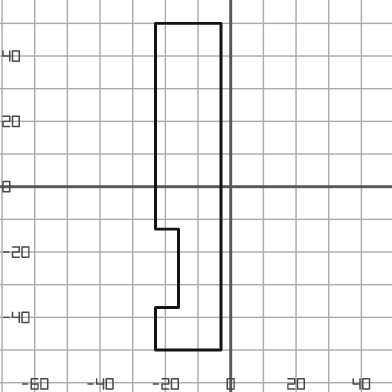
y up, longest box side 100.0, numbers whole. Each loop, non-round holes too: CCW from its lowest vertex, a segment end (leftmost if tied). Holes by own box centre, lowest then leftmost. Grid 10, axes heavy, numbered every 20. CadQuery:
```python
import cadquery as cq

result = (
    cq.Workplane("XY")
    .moveTo(-23.0, -50.0)
    .lineTo(-3.0, -50.0)
    .lineTo(-3.0, 50.0)
    .lineTo(-23.0, 50.0)
    .lineTo(-23.0, -13.0)
    .lineTo(-16.0, -13.0)
    .lineTo(-16.0, -37.0)
    .lineTo(-23.0, -37.0)
    .close()
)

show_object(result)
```